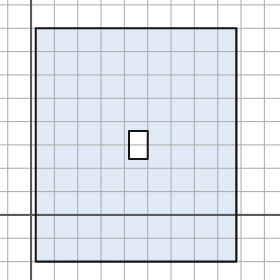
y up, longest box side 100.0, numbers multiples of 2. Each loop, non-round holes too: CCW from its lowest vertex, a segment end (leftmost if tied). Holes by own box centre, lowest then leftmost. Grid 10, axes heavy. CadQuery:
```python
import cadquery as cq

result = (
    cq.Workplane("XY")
    .moveTo(2.0, -20.0)
    .lineTo(88.0, -20.0)
    .lineTo(88.0, 80.0)
    .lineTo(2.0, 80.0)
    .close()
    .moveTo(42.0, 24.0)
    .lineTo(50.0, 24.0)
    .lineTo(50.0, 36.0)
    .lineTo(42.0, 36.0)
    .close()
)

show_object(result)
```